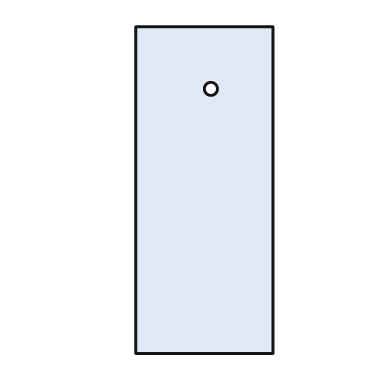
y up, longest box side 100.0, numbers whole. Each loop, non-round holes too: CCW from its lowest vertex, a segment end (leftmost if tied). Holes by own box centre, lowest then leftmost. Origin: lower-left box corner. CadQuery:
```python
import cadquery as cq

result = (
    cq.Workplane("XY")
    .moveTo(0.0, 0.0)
    .lineTo(42.0, 0.0)
    .lineTo(42.0, 100.0)
    .lineTo(0.0, 100.0)
    .close()
    .moveTo(23.0, 81.0)
    .circle(2.0)
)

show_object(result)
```